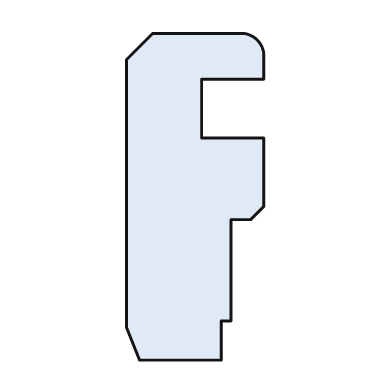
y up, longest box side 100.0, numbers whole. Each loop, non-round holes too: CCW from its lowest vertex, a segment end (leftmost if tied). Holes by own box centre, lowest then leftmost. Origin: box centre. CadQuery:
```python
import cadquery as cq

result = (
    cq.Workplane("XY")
    .moveTo(-17.0, -50.0)
    .lineTo(8.0, -50.0)
    .lineTo(8.0, -38.0)
    .lineTo(11.0, -38.0)
    .lineTo(11.0, -7.0)
    .lineTo(17.0, -7.0)
    .lineTo(21.0, -3.0)
    .lineTo(21.0, 18.0)
    .lineTo(2.0, 18.0)
    .lineTo(2.0, 36.0)
    .lineTo(21.0, 36.0)
    .lineTo(21.0, 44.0)
    .threePointArc((19.0, 48.0), (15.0, 50.0))
    .lineTo(-13.0, 50.0)
    .lineTo(-21.0, 42.0)
    .lineTo(-21.0, -40.0)
    .close()
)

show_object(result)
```